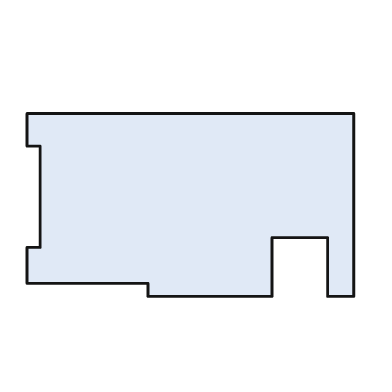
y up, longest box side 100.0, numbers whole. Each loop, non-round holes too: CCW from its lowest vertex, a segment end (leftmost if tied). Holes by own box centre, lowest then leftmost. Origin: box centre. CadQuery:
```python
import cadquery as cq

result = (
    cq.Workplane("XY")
    .moveTo(-13.0, -28.0)
    .lineTo(25.0, -28.0)
    .lineTo(25.0, -10.0)
    .lineTo(42.0, -10.0)
    .lineTo(42.0, -28.0)
    .lineTo(50.0, -28.0)
    .lineTo(50.0, 28.0)
    .lineTo(-50.0, 28.0)
    .lineTo(-50.0, 18.0)
    .lineTo(-46.0, 18.0)
    .lineTo(-46.0, -13.0)
    .lineTo(-50.0, -13.0)
    .lineTo(-50.0, -24.0)
    .lineTo(-13.0, -24.0)
    .close()
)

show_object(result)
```